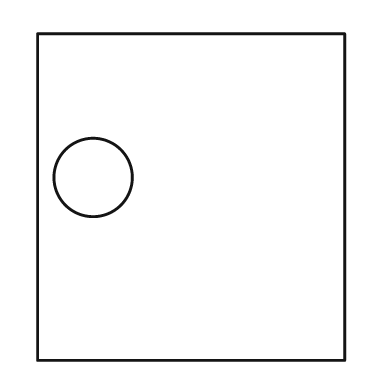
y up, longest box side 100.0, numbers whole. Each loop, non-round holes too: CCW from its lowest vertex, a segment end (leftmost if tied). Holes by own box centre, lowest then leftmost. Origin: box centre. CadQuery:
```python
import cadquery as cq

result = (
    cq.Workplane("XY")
    .moveTo(-47.0, -50.0)
    .lineTo(47.0, -50.0)
    .lineTo(47.0, 50.0)
    .lineTo(-47.0, 50.0)
    .close()
    .moveTo(-30.0, 6.0)
    .circle(12.0)
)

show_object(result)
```